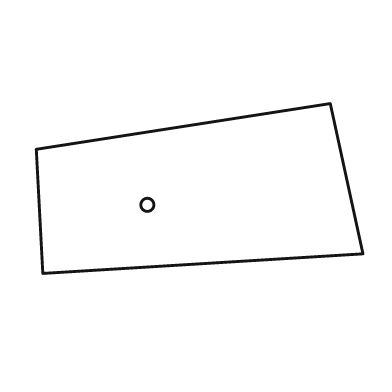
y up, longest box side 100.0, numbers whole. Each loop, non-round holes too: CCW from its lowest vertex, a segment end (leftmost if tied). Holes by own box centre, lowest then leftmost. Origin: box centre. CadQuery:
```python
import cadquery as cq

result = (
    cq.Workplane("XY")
    .moveTo(-48.0, -26.0)
    .lineTo(50.0, -20.0)
    .lineTo(40.0, 26.0)
    .lineTo(-50.0, 12.0)
    .close()
    .moveTo(-16.0, -5.0)
    .circle(2.0)
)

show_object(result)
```